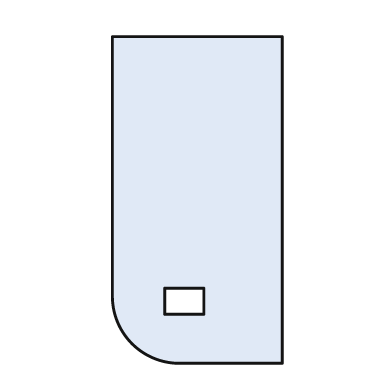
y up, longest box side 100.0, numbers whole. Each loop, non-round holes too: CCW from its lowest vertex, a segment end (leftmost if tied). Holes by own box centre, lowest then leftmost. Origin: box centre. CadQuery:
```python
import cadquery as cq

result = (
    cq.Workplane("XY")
    .moveTo(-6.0, -50.0)
    .lineTo(26.0, -50.0)
    .lineTo(26.0, 50.0)
    .lineTo(-26.0, 50.0)
    .lineTo(-26.0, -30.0)
    .threePointArc((-20.0, -44.0), (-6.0, -50.0))
    .close()
    .moveTo(-10.0, -35.0)
    .lineTo(2.0, -35.0)
    .lineTo(2.0, -27.0)
    .lineTo(-10.0, -27.0)
    .close()
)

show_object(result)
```